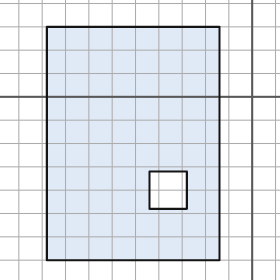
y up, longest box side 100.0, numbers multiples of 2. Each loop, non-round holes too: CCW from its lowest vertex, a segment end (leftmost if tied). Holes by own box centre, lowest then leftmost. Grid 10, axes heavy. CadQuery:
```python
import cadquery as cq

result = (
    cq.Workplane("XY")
    .moveTo(-88.0, -70.0)
    .lineTo(-14.0, -70.0)
    .lineTo(-14.0, 30.0)
    .lineTo(-88.0, 30.0)
    .close()
    .moveTo(-44.0, -48.0)
    .lineTo(-28.0, -48.0)
    .lineTo(-28.0, -32.0)
    .lineTo(-44.0, -32.0)
    .close()
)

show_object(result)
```